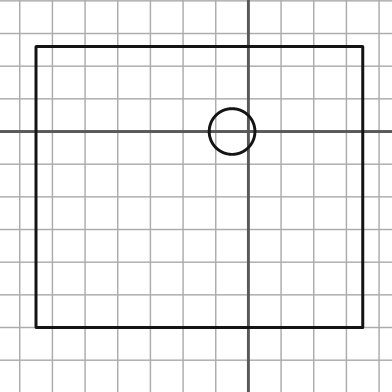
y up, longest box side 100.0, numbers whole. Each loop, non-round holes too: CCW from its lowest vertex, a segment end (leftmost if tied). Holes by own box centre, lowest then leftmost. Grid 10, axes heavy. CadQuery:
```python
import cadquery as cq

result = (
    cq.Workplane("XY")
    .moveTo(-65.0, -60.0)
    .lineTo(35.0, -60.0)
    .lineTo(35.0, 26.0)
    .lineTo(-65.0, 26.0)
    .close()
    .moveTo(-5.0, 0.0)
    .circle(7.0)
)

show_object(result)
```